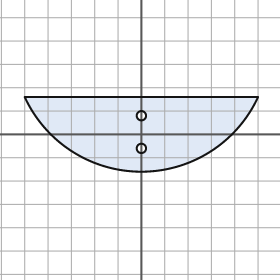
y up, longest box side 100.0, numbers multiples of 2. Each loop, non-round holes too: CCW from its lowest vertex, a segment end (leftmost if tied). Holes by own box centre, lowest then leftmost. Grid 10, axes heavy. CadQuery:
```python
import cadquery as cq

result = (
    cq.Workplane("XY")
    .moveTo(-50.0, 16.0)
    .threePointArc((0.0, -16.0), (50.0, 16.0))
    .close()
    .moveTo(0.0, -6.0)
    .circle(2.0)
    .moveTo(0.0, 8.0)
    .circle(2.0)
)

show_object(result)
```